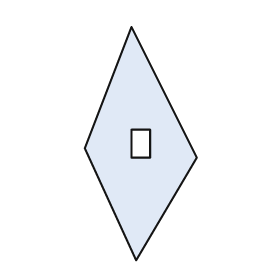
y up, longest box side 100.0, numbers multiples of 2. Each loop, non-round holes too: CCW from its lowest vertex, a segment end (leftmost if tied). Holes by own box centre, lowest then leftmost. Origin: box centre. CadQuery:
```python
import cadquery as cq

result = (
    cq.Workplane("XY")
    .moveTo(-2.0, -50.0)
    .lineTo(24.0, -6.0)
    .lineTo(-4.0, 50.0)
    .lineTo(-24.0, -2.0)
    .close()
    .moveTo(-4.0, -6.0)
    .lineTo(4.0, -6.0)
    .lineTo(4.0, 6.0)
    .lineTo(-4.0, 6.0)
    .close()
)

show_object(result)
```